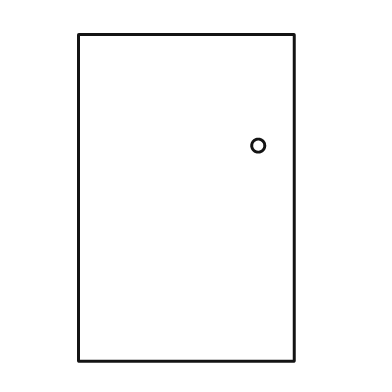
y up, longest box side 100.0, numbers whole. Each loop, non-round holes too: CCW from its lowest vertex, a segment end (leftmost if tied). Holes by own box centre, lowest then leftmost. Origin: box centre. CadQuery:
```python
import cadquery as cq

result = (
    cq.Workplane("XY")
    .moveTo(-33.0, -50.0)
    .lineTo(33.0, -50.0)
    .lineTo(33.0, 50.0)
    .lineTo(-33.0, 50.0)
    .close()
    .moveTo(22.0, 16.0)
    .circle(2.0)
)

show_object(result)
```